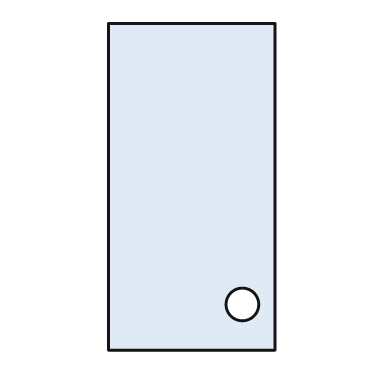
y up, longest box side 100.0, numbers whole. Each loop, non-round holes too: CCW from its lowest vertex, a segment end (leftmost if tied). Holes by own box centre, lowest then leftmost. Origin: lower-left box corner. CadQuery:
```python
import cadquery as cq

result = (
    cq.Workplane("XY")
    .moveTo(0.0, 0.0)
    .lineTo(51.0, 0.0)
    .lineTo(51.0, 100.0)
    .lineTo(0.0, 100.0)
    .close()
    .moveTo(41.0, 14.0)
    .circle(5.0)
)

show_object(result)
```